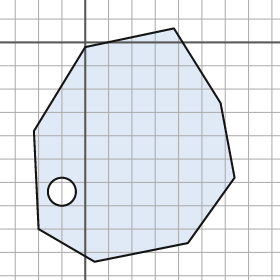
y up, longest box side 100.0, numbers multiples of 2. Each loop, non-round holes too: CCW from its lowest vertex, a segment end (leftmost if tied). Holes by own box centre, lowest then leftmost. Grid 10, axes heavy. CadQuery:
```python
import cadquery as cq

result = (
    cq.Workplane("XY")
    .moveTo(4.0, -94.0)
    .lineTo(44.0, -86.0)
    .lineTo(64.0, -58.0)
    .lineTo(58.0, -26.0)
    .lineTo(38.0, 6.0)
    .lineTo(0.0, -2.0)
    .lineTo(-22.0, -38.0)
    .lineTo(-20.0, -80.0)
    .close()
    .moveTo(-10.0, -64.0)
    .circle(6.0)
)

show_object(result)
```